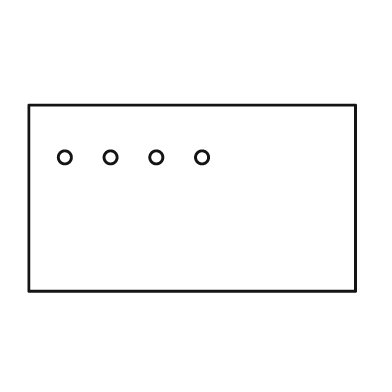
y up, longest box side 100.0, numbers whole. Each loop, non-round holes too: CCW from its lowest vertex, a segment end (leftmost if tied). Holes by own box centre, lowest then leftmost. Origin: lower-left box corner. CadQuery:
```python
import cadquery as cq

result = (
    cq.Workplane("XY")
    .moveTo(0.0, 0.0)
    .lineTo(100.0, 0.0)
    .lineTo(100.0, 57.0)
    .lineTo(0.0, 57.0)
    .close()
    .moveTo(11.0, 41.0)
    .circle(2.0)
    .moveTo(25.0, 41.0)
    .circle(2.0)
    .moveTo(39.0, 41.0)
    .circle(2.0)
    .moveTo(53.0, 41.0)
    .circle(2.0)
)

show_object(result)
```